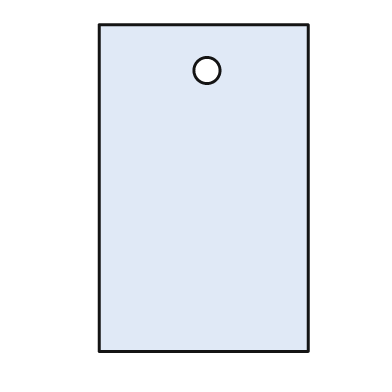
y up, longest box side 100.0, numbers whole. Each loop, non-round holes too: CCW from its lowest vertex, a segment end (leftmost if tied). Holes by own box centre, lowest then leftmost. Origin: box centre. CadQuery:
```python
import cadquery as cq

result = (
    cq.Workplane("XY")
    .moveTo(-32.0, -50.0)
    .lineTo(32.0, -50.0)
    .lineTo(32.0, 50.0)
    .lineTo(-32.0, 50.0)
    .close()
    .moveTo(1.0, 36.0)
    .circle(4.0)
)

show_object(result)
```